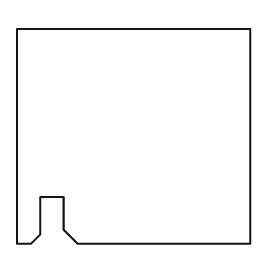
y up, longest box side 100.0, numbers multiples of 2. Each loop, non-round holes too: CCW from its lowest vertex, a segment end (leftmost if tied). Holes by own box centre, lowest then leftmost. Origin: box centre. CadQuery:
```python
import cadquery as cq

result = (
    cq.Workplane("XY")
    .moveTo(-50.0, -46.0)
    .lineTo(-44.0, -46.0)
    .lineTo(-40.0, -42.0)
    .lineTo(-40.0, -26.0)
    .lineTo(-30.0, -26.0)
    .lineTo(-30.0, -40.0)
    .lineTo(-24.0, -46.0)
    .lineTo(50.0, -46.0)
    .lineTo(50.0, 46.0)
    .lineTo(-50.0, 46.0)
    .close()
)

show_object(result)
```